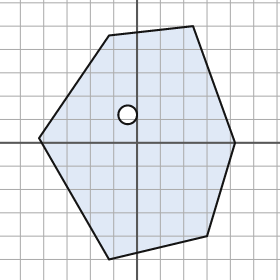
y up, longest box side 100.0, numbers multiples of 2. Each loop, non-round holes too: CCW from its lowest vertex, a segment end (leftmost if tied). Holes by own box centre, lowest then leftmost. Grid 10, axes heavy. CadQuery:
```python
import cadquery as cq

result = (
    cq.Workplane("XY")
    .moveTo(-12.0, -50.0)
    .lineTo(30.0, -40.0)
    .lineTo(42.0, 0.0)
    .lineTo(24.0, 50.0)
    .lineTo(-12.0, 46.0)
    .lineTo(-42.0, 2.0)
    .close()
    .moveTo(-4.0, 12.0)
    .circle(4.0)
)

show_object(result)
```